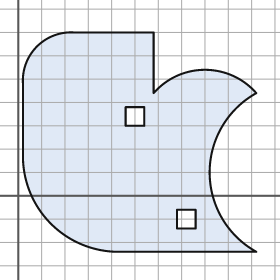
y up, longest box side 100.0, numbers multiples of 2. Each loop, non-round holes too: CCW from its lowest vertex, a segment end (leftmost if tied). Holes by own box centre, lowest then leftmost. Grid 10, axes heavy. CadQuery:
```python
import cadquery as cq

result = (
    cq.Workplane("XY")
    .moveTo(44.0, -24.0)
    .lineTo(102.0, -24.0)
    .threePointArc((82.0, 10.0), (102.0, 44.0))
    .threePointArc((80.0, 54.0), (58.0, 44.0))
    .lineTo(58.0, 70.0)
    .lineTo(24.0, 70.0)
    .threePointArc((8.0, 64.0), (2.0, 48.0))
    .lineTo(2.0, 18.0)
    .threePointArc((14.0, -12.0), (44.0, -24.0))
    .close()
    .moveTo(68.0, -14.0)
    .lineTo(76.0, -14.0)
    .lineTo(76.0, -6.0)
    .lineTo(68.0, -6.0)
    .close()
    .moveTo(46.0, 30.0)
    .lineTo(54.0, 30.0)
    .lineTo(54.0, 38.0)
    .lineTo(46.0, 38.0)
    .close()
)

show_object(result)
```